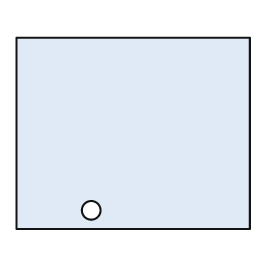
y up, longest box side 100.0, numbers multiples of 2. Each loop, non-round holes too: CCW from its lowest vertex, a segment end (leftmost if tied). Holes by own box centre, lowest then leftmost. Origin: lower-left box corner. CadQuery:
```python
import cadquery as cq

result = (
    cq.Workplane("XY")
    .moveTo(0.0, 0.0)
    .lineTo(100.0, 0.0)
    .lineTo(100.0, 82.0)
    .lineTo(0.0, 82.0)
    .close()
    .moveTo(32.0, 8.0)
    .circle(4.0)
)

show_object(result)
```